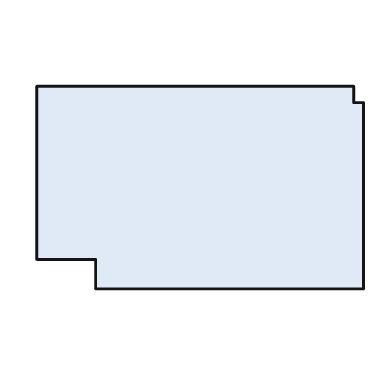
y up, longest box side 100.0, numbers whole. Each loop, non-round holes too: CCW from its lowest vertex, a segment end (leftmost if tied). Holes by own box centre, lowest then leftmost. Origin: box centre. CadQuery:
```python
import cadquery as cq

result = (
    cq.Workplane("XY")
    .moveTo(-32.0, -31.0)
    .lineTo(50.0, -31.0)
    .lineTo(50.0, 26.0)
    .lineTo(47.0, 26.0)
    .lineTo(47.0, 31.0)
    .lineTo(-50.0, 31.0)
    .lineTo(-50.0, -22.0)
    .lineTo(-32.0, -22.0)
    .close()
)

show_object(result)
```